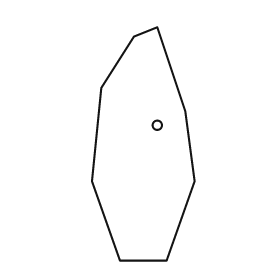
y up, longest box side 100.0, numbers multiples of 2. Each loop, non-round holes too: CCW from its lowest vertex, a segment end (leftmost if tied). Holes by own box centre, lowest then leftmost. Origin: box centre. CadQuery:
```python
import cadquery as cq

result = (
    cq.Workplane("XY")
    .moveTo(-10.0, -50.0)
    .lineTo(10.0, -50.0)
    .lineTo(22.0, -16.0)
    .lineTo(18.0, 14.0)
    .lineTo(6.0, 50.0)
    .lineTo(-4.0, 46.0)
    .lineTo(-18.0, 24.0)
    .lineTo(-22.0, -16.0)
    .close()
    .moveTo(6.0, 8.0)
    .circle(2.0)
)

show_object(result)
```